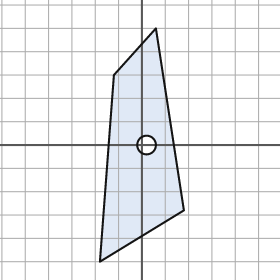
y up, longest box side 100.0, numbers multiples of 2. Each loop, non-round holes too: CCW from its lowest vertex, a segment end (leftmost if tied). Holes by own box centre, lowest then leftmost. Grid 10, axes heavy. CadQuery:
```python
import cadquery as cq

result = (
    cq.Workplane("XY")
    .moveTo(-18.0, -50.0)
    .lineTo(18.0, -28.0)
    .lineTo(6.0, 50.0)
    .lineTo(-12.0, 30.0)
    .close()
    .moveTo(2.0, 0.0)
    .circle(4.0)
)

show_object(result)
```